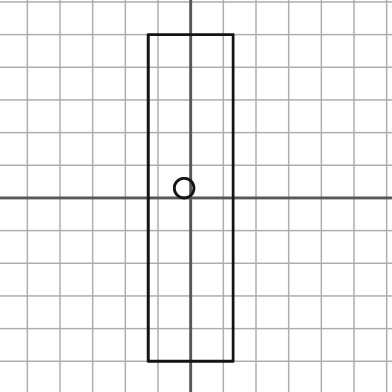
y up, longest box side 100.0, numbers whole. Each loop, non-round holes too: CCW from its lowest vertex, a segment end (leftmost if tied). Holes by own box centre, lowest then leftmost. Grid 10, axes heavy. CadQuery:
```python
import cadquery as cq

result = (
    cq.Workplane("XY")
    .moveTo(-13.0, -50.0)
    .lineTo(13.0, -50.0)
    .lineTo(13.0, 50.0)
    .lineTo(-13.0, 50.0)
    .close()
    .moveTo(-2.0, 3.0)
    .circle(3.0)
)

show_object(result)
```